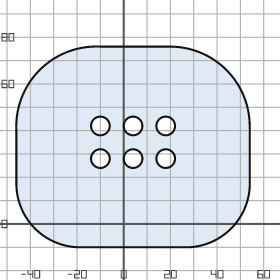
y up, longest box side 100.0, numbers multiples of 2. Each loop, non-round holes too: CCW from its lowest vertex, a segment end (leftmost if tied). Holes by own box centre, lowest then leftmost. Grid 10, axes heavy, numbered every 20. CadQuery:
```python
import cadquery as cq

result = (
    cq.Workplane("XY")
    .moveTo(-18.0, -10.0)
    .lineTo(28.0, -10.0)
    .threePointArc((46.0, -2.0), (54.0, 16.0))
    .lineTo(54.0, 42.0)
    .threePointArc((44.0, 66.0), (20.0, 76.0))
    .lineTo(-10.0, 76.0)
    .threePointArc((-36.0, 66.0), (-46.0, 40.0))
    .lineTo(-46.0, 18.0)
    .threePointArc((-38.0, -2.0), (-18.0, -10.0))
    .close()
    .moveTo(-10.0, 28.0)
    .circle(4.0)
    .moveTo(4.0, 28.0)
    .circle(4.0)
    .moveTo(18.0, 28.0)
    .circle(4.0)
    .moveTo(-10.0, 42.0)
    .circle(4.0)
    .moveTo(4.0, 42.0)
    .circle(4.0)
    .moveTo(18.0, 42.0)
    .circle(4.0)
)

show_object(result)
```